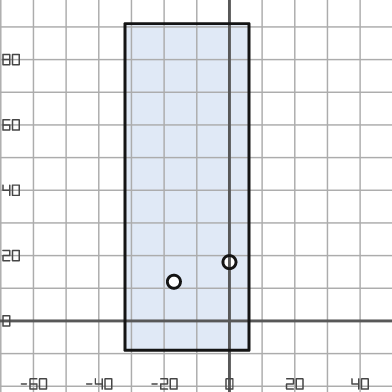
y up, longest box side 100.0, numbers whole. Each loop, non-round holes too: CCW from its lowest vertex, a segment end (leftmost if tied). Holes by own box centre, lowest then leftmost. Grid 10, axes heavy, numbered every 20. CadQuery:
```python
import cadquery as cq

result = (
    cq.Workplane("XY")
    .moveTo(-32.0, -9.0)
    .lineTo(6.0, -9.0)
    .lineTo(6.0, 91.0)
    .lineTo(-32.0, 91.0)
    .close()
    .moveTo(-17.0, 12.0)
    .circle(2.0)
    .moveTo(0.0, 18.0)
    .circle(2.0)
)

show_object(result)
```